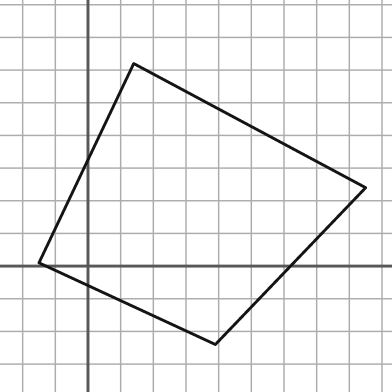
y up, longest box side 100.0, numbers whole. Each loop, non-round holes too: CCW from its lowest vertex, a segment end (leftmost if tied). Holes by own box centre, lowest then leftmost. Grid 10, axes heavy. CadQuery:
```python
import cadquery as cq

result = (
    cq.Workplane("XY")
    .moveTo(39.0, -24.0)
    .lineTo(85.0, 24.0)
    .lineTo(14.0, 62.0)
    .lineTo(-15.0, 1.0)
    .close()
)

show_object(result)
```